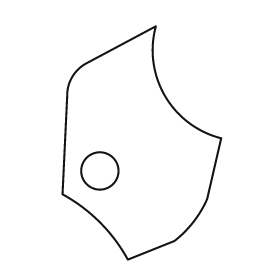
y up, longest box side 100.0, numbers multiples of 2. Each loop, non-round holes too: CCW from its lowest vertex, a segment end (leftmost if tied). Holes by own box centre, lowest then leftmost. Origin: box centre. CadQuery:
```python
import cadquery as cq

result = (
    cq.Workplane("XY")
    .moveTo(-6.0, -50.0)
    .lineTo(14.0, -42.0)
    .threePointArc((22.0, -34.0), (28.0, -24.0))
    .lineTo(34.0, 2.0)
    .threePointArc((10.0, 20.0), (6.0, 50.0))
    .lineTo(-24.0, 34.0)
    .threePointArc((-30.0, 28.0), (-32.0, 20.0))
    .lineTo(-34.0, -22.0)
    .threePointArc((-18.0, -34.0), (-6.0, -50.0))
    .close()
    .moveTo(-18.0, -12.0)
    .circle(8.0)
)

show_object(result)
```